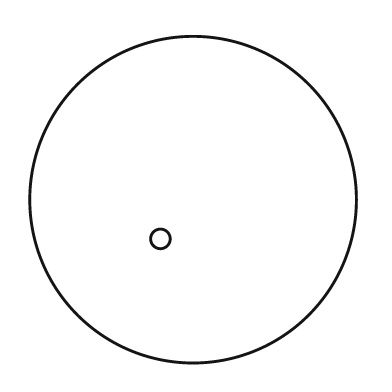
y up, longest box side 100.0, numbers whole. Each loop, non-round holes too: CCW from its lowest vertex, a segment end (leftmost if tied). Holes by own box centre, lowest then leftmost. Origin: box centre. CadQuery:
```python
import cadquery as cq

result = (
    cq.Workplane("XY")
    .moveTo(0.0, 0.0)
    .circle(50.0)
    .moveTo(-10.0, -12.0)
    .circle(3.0)
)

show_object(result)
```